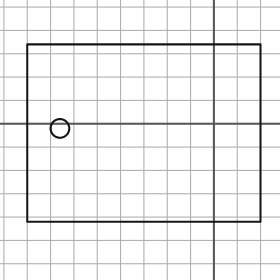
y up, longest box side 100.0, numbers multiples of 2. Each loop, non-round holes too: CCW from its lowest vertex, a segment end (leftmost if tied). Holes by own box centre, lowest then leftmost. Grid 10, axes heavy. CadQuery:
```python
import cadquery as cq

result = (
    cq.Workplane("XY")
    .moveTo(-80.0, -42.0)
    .lineTo(20.0, -42.0)
    .lineTo(20.0, 34.0)
    .lineTo(-80.0, 34.0)
    .close()
    .moveTo(-66.0, -2.0)
    .circle(4.0)
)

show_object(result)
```